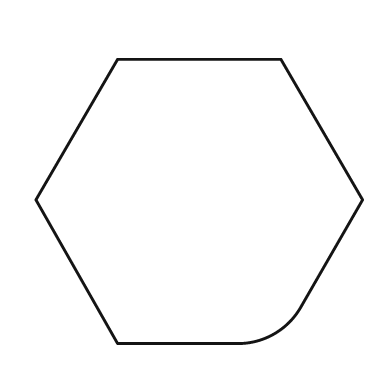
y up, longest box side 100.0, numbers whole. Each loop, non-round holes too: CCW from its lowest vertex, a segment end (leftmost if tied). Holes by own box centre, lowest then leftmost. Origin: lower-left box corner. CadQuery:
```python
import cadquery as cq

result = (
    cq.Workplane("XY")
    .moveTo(25.0, 0.0)
    .lineTo(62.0, 0.0)
    .threePointArc((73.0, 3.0), (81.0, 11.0))
    .lineTo(100.0, 44.0)
    .lineTo(75.0, 87.0)
    .lineTo(25.0, 87.0)
    .lineTo(0.0, 44.0)
    .close()
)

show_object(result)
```